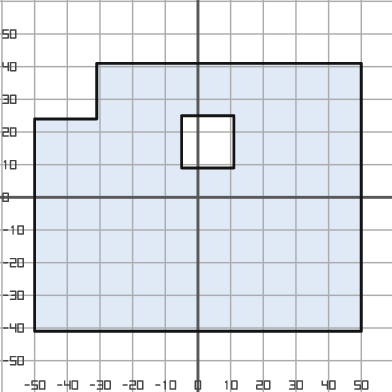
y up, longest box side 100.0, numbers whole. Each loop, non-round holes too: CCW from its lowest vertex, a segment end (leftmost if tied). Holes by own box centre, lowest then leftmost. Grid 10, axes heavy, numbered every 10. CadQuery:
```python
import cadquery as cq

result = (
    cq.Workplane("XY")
    .moveTo(-50.0, -41.0)
    .lineTo(50.0, -41.0)
    .lineTo(50.0, 41.0)
    .lineTo(-31.0, 41.0)
    .lineTo(-31.0, 24.0)
    .lineTo(-50.0, 24.0)
    .close()
    .moveTo(-5.0, 9.0)
    .lineTo(11.0, 9.0)
    .lineTo(11.0, 25.0)
    .lineTo(-5.0, 25.0)
    .close()
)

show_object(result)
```